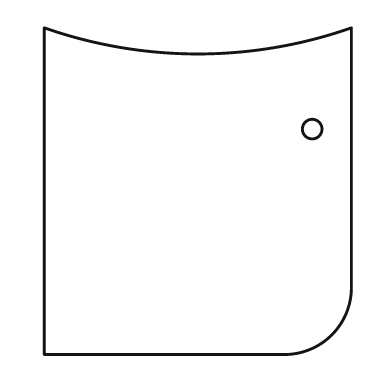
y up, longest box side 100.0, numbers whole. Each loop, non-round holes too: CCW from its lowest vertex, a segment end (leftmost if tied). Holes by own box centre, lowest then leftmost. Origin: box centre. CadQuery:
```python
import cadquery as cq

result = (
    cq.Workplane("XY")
    .moveTo(-47.0, -50.0)
    .lineTo(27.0, -50.0)
    .threePointArc((41.0, -44.0), (47.0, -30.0))
    .lineTo(47.0, 50.0)
    .threePointArc((0.0, 42.0), (-47.0, 50.0))
    .close()
    .moveTo(35.0, 19.0)
    .circle(3.0)
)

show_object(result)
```